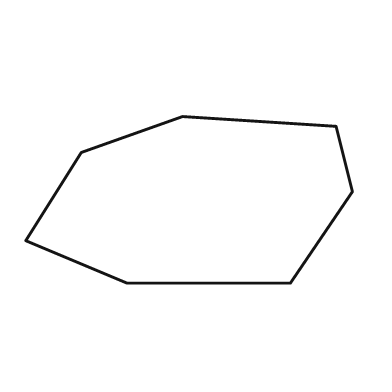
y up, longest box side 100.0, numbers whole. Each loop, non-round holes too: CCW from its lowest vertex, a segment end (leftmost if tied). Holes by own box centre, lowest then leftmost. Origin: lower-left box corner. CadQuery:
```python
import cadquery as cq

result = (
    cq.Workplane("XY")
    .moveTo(31.0, 0.0)
    .lineTo(81.0, 0.0)
    .lineTo(100.0, 28.0)
    .lineTo(95.0, 48.0)
    .lineTo(48.0, 51.0)
    .lineTo(17.0, 40.0)
    .lineTo(0.0, 13.0)
    .close()
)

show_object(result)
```